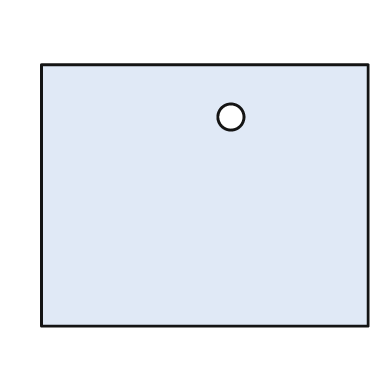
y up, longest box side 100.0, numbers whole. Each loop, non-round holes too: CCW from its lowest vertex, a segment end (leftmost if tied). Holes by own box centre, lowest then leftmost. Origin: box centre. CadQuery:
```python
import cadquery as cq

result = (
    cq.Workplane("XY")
    .moveTo(-50.0, -40.0)
    .lineTo(50.0, -40.0)
    .lineTo(50.0, 40.0)
    .lineTo(-50.0, 40.0)
    .close()
    .moveTo(8.0, 24.0)
    .circle(4.0)
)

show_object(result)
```